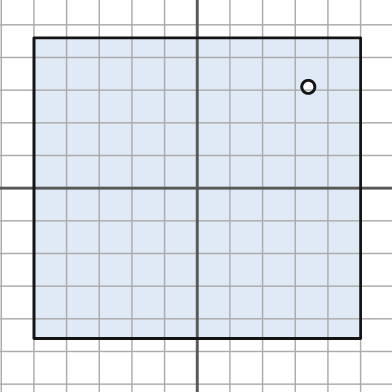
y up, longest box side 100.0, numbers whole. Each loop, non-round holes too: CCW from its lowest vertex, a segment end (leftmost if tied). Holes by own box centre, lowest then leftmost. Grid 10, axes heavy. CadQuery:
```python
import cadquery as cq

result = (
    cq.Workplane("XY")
    .moveTo(-50.0, -46.0)
    .lineTo(50.0, -46.0)
    .lineTo(50.0, 46.0)
    .lineTo(-50.0, 46.0)
    .close()
    .moveTo(34.0, 31.0)
    .circle(2.0)
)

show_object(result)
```